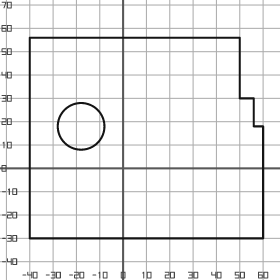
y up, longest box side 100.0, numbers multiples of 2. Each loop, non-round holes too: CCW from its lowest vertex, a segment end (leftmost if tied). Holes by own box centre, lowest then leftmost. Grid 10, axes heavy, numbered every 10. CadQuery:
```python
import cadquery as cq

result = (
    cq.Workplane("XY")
    .moveTo(-40.0, -30.0)
    .lineTo(60.0, -30.0)
    .lineTo(60.0, 18.0)
    .lineTo(56.0, 18.0)
    .lineTo(56.0, 30.0)
    .lineTo(50.0, 30.0)
    .lineTo(50.0, 56.0)
    .lineTo(-40.0, 56.0)
    .close()
    .moveTo(-18.0, 18.0)
    .circle(10.0)
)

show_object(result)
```